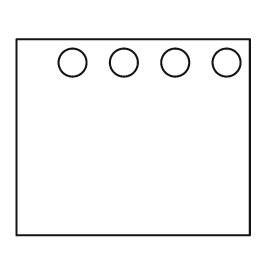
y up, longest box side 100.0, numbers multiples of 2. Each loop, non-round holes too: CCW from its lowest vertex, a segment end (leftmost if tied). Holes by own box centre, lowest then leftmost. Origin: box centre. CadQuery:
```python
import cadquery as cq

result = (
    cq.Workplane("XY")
    .moveTo(-50.0, -42.0)
    .lineTo(50.0, -42.0)
    .lineTo(50.0, 42.0)
    .lineTo(-50.0, 42.0)
    .close()
    .moveTo(-26.0, 32.0)
    .circle(6.0)
    .moveTo(-4.0, 32.0)
    .circle(6.0)
    .moveTo(18.0, 32.0)
    .circle(6.0)
    .moveTo(40.0, 32.0)
    .circle(6.0)
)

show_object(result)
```